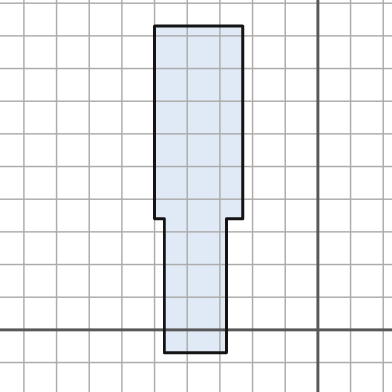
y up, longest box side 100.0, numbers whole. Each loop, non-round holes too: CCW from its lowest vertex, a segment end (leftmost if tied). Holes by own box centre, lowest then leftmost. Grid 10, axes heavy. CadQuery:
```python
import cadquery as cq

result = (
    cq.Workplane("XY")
    .moveTo(-47.0, -7.0)
    .lineTo(-28.0, -7.0)
    .lineTo(-28.0, 34.0)
    .lineTo(-23.0, 34.0)
    .lineTo(-23.0, 93.0)
    .lineTo(-50.0, 93.0)
    .lineTo(-50.0, 34.0)
    .lineTo(-47.0, 34.0)
    .close()
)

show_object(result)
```